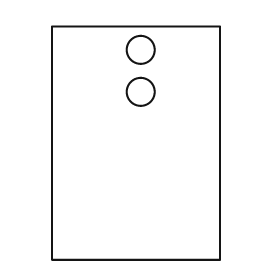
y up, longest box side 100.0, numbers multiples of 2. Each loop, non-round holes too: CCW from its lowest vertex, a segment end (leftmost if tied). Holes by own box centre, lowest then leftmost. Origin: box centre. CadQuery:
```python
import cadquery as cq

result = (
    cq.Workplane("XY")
    .moveTo(-36.0, -50.0)
    .lineTo(36.0, -50.0)
    .lineTo(36.0, 50.0)
    .lineTo(-36.0, 50.0)
    .close()
    .moveTo(2.0, 22.0)
    .circle(6.0)
    .moveTo(2.0, 40.0)
    .circle(6.0)
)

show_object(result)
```